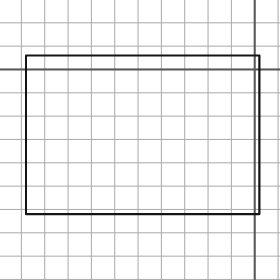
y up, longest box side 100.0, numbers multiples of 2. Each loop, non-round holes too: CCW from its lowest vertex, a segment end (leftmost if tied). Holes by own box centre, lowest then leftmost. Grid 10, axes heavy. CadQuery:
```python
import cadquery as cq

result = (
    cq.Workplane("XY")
    .moveTo(-98.0, -62.0)
    .lineTo(2.0, -62.0)
    .lineTo(2.0, 6.0)
    .lineTo(-98.0, 6.0)
    .close()
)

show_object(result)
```